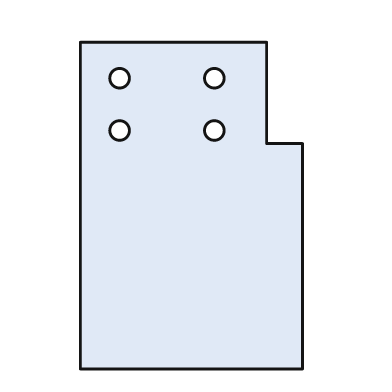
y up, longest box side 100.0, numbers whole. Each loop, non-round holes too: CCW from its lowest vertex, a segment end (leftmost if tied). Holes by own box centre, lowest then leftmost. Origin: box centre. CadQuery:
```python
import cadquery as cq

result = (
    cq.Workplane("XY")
    .moveTo(-34.0, -50.0)
    .lineTo(34.0, -50.0)
    .lineTo(34.0, 19.0)
    .lineTo(23.0, 19.0)
    .lineTo(23.0, 50.0)
    .lineTo(-34.0, 50.0)
    .close()
    .moveTo(-22.0, 23.0)
    .circle(3.0)
    .moveTo(7.0, 23.0)
    .circle(3.0)
    .moveTo(-22.0, 39.0)
    .circle(3.0)
    .moveTo(7.0, 39.0)
    .circle(3.0)
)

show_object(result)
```